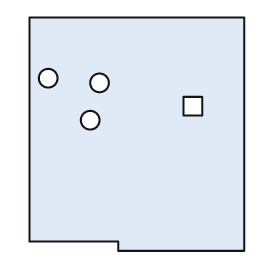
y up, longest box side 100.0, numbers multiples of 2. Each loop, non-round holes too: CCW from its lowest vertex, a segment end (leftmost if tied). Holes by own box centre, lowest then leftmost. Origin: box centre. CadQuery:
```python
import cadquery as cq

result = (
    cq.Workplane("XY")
    .moveTo(-8.0, -50.0)
    .lineTo(46.0, -50.0)
    .lineTo(46.0, 50.0)
    .lineTo(-46.0, 50.0)
    .lineTo(-46.0, -46.0)
    .lineTo(-8.0, -46.0)
    .close()
    .moveTo(-20.0, 6.0)
    .circle(4.0)
    .moveTo(20.0, 8.0)
    .lineTo(28.0, 8.0)
    .lineTo(28.0, 16.0)
    .lineTo(20.0, 16.0)
    .close()
    .moveTo(-16.0, 22.0)
    .circle(4.0)
    .moveTo(-38.0, 24.0)
    .circle(4.0)
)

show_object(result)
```